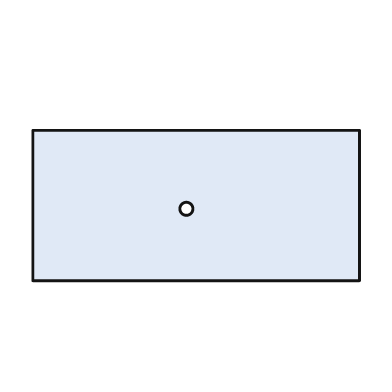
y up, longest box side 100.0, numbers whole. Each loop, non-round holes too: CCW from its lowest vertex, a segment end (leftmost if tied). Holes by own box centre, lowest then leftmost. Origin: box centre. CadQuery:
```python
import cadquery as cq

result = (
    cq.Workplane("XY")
    .moveTo(-50.0, -23.0)
    .lineTo(50.0, -23.0)
    .lineTo(50.0, 23.0)
    .lineTo(-50.0, 23.0)
    .close()
    .moveTo(-3.0, -1.0)
    .circle(2.0)
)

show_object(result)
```